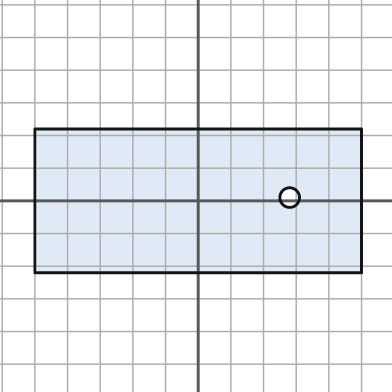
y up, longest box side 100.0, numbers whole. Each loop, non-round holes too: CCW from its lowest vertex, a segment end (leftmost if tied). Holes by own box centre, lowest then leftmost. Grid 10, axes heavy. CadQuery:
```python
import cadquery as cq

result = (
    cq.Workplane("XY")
    .moveTo(-50.0, -22.0)
    .lineTo(50.0, -22.0)
    .lineTo(50.0, 22.0)
    .lineTo(-50.0, 22.0)
    .close()
    .moveTo(28.0, 1.0)
    .circle(3.0)
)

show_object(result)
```